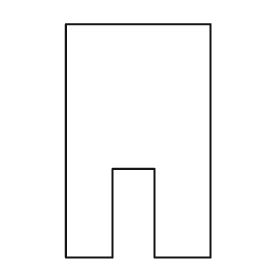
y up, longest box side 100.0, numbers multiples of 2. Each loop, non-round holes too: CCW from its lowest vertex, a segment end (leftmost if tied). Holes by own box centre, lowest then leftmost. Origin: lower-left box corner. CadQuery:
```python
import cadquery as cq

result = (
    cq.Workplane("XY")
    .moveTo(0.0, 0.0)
    .lineTo(20.0, 0.0)
    .lineTo(20.0, 38.0)
    .lineTo(38.0, 38.0)
    .lineTo(38.0, 0.0)
    .lineTo(62.0, 0.0)
    .lineTo(62.0, 100.0)
    .lineTo(0.0, 100.0)
    .close()
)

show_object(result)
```